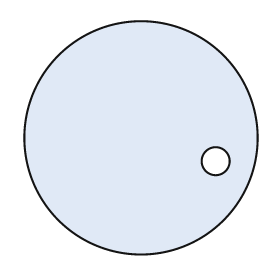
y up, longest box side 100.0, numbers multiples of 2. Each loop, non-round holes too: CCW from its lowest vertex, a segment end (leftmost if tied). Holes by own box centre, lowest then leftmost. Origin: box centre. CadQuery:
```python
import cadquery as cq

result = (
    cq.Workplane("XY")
    .moveTo(0.0, 0.0)
    .circle(50.0)
    .moveTo(32.0, -10.0)
    .circle(6.0)
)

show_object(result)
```